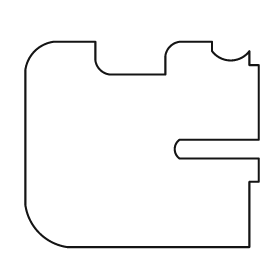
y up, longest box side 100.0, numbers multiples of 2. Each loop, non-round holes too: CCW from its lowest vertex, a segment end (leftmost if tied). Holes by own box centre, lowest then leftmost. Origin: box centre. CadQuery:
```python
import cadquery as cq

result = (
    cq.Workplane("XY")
    .moveTo(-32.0, -44.0)
    .lineTo(46.0, -44.0)
    .lineTo(46.0, -16.0)
    .lineTo(50.0, -16.0)
    .lineTo(50.0, -6.0)
    .lineTo(16.0, -6.0)
    .threePointArc((14.0, -2.0), (16.0, 2.0))
    .lineTo(50.0, 2.0)
    .lineTo(50.0, 34.0)
    .lineTo(46.0, 34.0)
    .lineTo(46.0, 40.0)
    .threePointArc((38.0, 36.0), (30.0, 40.0))
    .lineTo(30.0, 44.0)
    .lineTo(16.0, 44.0)
    .threePointArc((12.0, 42.0), (10.0, 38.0))
    .lineTo(10.0, 30.0)
    .lineTo(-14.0, 30.0)
    .threePointArc((-18.0, 32.0), (-20.0, 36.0))
    .lineTo(-20.0, 44.0)
    .lineTo(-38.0, 44.0)
    .threePointArc((-46.0, 40.0), (-50.0, 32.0))
    .lineTo(-50.0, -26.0)
    .threePointArc((-44.0, -38.0), (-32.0, -44.0))
    .close()
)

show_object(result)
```